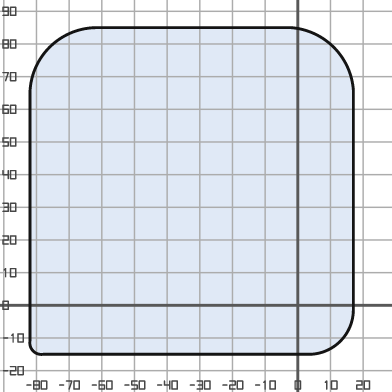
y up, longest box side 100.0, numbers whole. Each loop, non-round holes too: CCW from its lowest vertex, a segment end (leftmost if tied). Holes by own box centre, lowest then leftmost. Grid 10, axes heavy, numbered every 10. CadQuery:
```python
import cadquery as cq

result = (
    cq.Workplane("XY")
    .moveTo(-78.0, -15.0)
    .lineTo(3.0, -15.0)
    .threePointArc((13.0, -11.0), (17.0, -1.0))
    .lineTo(17.0, 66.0)
    .threePointArc((11.0, 79.0), (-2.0, 85.0))
    .lineTo(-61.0, 85.0)
    .threePointArc((-76.0, 79.0), (-82.0, 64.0))
    .lineTo(-82.0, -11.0)
    .threePointArc((-81.0, -14.0), (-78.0, -15.0))
    .close()
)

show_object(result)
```